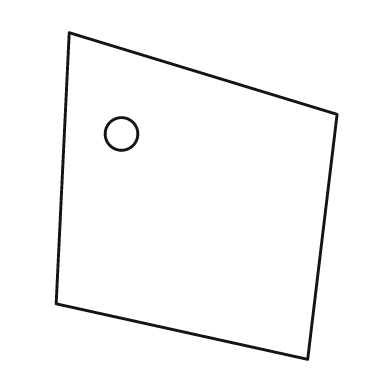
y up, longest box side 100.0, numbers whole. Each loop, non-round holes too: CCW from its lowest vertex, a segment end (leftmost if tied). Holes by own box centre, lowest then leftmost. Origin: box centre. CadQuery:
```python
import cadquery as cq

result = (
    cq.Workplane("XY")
    .moveTo(34.0, -50.0)
    .lineTo(43.0, 25.0)
    .lineTo(-39.0, 50.0)
    .lineTo(-43.0, -33.0)
    .close()
    .moveTo(-23.0, 19.0)
    .circle(5.0)
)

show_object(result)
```